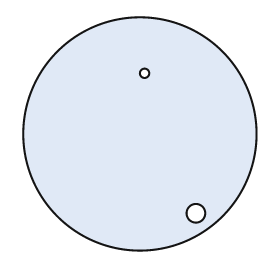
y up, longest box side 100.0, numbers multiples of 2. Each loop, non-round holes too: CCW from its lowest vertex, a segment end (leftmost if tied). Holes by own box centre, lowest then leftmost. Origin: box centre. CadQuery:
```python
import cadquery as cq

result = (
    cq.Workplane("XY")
    .moveTo(0.0, 0.0)
    .circle(50.0)
    .moveTo(24.0, -34.0)
    .circle(4.0)
    .moveTo(2.0, 26.0)
    .circle(2.0)
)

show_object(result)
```